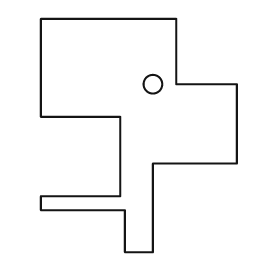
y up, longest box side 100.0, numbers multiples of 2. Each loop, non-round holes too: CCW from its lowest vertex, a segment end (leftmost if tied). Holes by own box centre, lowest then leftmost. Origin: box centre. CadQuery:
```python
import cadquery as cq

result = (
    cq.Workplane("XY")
    .moveTo(-6.0, -50.0)
    .lineTo(6.0, -50.0)
    .lineTo(6.0, -12.0)
    .lineTo(42.0, -12.0)
    .lineTo(42.0, 22.0)
    .lineTo(16.0, 22.0)
    .lineTo(16.0, 50.0)
    .lineTo(-42.0, 50.0)
    .lineTo(-42.0, 8.0)
    .lineTo(-8.0, 8.0)
    .lineTo(-8.0, -26.0)
    .lineTo(-42.0, -26.0)
    .lineTo(-42.0, -32.0)
    .lineTo(-6.0, -32.0)
    .close()
    .moveTo(6.0, 22.0)
    .circle(4.0)
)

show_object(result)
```